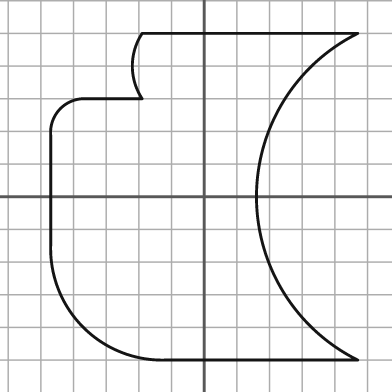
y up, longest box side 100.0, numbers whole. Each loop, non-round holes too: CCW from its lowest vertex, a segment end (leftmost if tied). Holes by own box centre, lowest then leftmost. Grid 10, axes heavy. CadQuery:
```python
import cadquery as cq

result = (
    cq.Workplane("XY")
    .moveTo(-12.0, -50.0)
    .lineTo(47.0, -50.0)
    .threePointArc((16.0, 0.0), (47.0, 50.0))
    .lineTo(-19.0, 50.0)
    .threePointArc((-22.0, 40.0), (-19.0, 30.0))
    .lineTo(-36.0, 30.0)
    .threePointArc((-44.0, 27.0), (-47.0, 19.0))
    .lineTo(-47.0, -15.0)
    .threePointArc((-37.0, -40.0), (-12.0, -50.0))
    .close()
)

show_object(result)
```